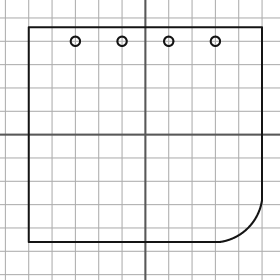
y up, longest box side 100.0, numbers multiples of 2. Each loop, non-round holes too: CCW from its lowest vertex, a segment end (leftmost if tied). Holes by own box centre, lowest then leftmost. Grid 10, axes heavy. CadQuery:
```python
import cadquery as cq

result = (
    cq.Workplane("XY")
    .moveTo(-50.0, -46.0)
    .lineTo(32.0, -46.0)
    .threePointArc((44.0, -40.0), (50.0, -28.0))
    .lineTo(50.0, 46.0)
    .lineTo(-50.0, 46.0)
    .close()
    .moveTo(-30.0, 40.0)
    .circle(2.0)
    .moveTo(-10.0, 40.0)
    .circle(2.0)
    .moveTo(10.0, 40.0)
    .circle(2.0)
    .moveTo(30.0, 40.0)
    .circle(2.0)
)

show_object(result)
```